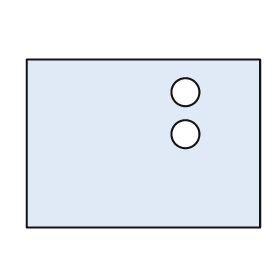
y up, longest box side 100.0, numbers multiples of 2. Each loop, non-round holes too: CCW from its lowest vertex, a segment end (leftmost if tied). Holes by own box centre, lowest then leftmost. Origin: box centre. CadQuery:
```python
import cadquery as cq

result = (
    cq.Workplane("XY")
    .moveTo(-50.0, -36.0)
    .lineTo(50.0, -36.0)
    .lineTo(50.0, 36.0)
    .lineTo(-50.0, 36.0)
    .close()
    .moveTo(18.0, 4.0)
    .circle(6.0)
    .moveTo(18.0, 22.0)
    .circle(6.0)
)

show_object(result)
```